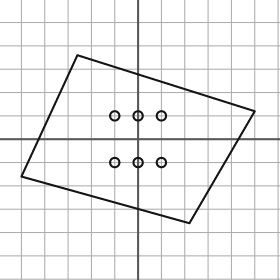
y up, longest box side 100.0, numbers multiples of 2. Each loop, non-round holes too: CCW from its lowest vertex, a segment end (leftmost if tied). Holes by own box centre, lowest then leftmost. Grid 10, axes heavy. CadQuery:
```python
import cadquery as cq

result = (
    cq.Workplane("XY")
    .moveTo(22.0, -36.0)
    .lineTo(50.0, 12.0)
    .lineTo(-26.0, 36.0)
    .lineTo(-50.0, -16.0)
    .close()
    .moveTo(-10.0, -10.0)
    .circle(2.0)
    .moveTo(0.0, -10.0)
    .circle(2.0)
    .moveTo(10.0, -10.0)
    .circle(2.0)
    .moveTo(-10.0, 10.0)
    .circle(2.0)
    .moveTo(0.0, 10.0)
    .circle(2.0)
    .moveTo(10.0, 10.0)
    .circle(2.0)
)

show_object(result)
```